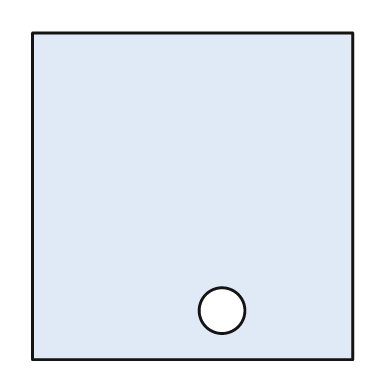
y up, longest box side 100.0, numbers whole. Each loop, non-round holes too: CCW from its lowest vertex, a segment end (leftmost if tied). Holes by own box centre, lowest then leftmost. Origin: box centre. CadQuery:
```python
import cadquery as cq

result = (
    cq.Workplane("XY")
    .moveTo(-49.0, -50.0)
    .lineTo(49.0, -50.0)
    .lineTo(49.0, 50.0)
    .lineTo(-49.0, 50.0)
    .close()
    .moveTo(9.0, -35.0)
    .circle(7.0)
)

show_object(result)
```